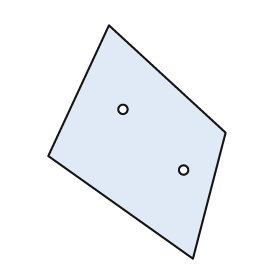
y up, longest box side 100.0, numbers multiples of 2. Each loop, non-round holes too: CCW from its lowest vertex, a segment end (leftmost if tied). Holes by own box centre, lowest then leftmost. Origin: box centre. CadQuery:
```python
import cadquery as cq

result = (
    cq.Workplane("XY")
    .moveTo(24.0, -50.0)
    .lineTo(38.0, 4.0)
    .lineTo(-12.0, 50.0)
    .lineTo(-38.0, -6.0)
    .close()
    .moveTo(20.0, -12.0)
    .circle(2.0)
    .moveTo(-6.0, 14.0)
    .circle(2.0)
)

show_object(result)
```